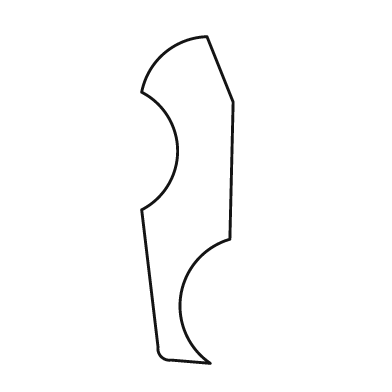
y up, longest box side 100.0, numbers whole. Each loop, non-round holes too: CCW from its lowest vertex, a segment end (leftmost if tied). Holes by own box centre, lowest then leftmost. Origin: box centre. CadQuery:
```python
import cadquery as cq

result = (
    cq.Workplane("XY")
    .moveTo(7.0, -50.0)
    .threePointArc((-2.0, -29.0), (13.0, -12.0))
    .lineTo(14.0, 30.0)
    .lineTo(6.0, 50.0)
    .threePointArc((-7.0, 45.0), (-14.0, 33.0))
    .threePointArc((-3.0, 15.0), (-14.0, -3.0))
    .lineTo(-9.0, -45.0)
    .threePointArc((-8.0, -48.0), (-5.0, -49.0))
    .close()
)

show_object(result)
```